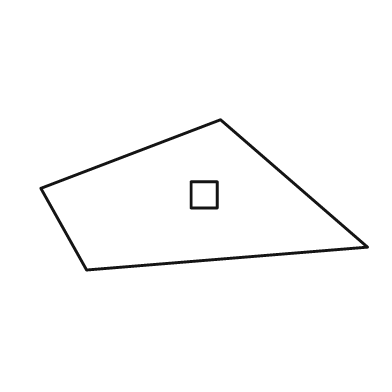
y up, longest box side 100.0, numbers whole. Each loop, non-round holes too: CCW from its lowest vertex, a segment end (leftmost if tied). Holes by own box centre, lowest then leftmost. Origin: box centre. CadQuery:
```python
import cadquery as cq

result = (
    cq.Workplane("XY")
    .moveTo(-36.0, -23.0)
    .lineTo(50.0, -16.0)
    .lineTo(5.0, 23.0)
    .lineTo(-50.0, 2.0)
    .close()
    .moveTo(-4.0, -4.0)
    .lineTo(4.0, -4.0)
    .lineTo(4.0, 4.0)
    .lineTo(-4.0, 4.0)
    .close()
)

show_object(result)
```